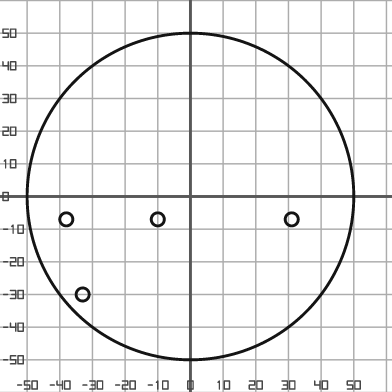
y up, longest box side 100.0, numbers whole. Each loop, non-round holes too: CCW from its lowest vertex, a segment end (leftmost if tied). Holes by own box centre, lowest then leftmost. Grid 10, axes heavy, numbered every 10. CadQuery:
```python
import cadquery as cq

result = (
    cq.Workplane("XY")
    .moveTo(0.0, 0.0)
    .circle(50.0)
    .moveTo(-33.0, -30.0)
    .circle(2.0)
    .moveTo(-38.0, -7.0)
    .circle(2.0)
    .moveTo(-10.0, -7.0)
    .circle(2.0)
    .moveTo(31.0, -7.0)
    .circle(2.0)
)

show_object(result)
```